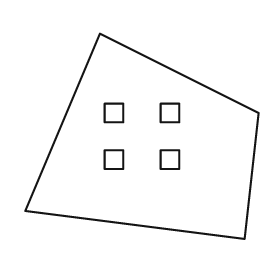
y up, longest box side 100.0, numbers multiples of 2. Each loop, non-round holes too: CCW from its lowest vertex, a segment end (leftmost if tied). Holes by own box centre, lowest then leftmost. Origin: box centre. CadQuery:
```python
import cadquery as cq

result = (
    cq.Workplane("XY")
    .moveTo(44.0, -44.0)
    .lineTo(50.0, 10.0)
    .lineTo(-18.0, 44.0)
    .lineTo(-50.0, -32.0)
    .close()
    .moveTo(-16.0, -14.0)
    .lineTo(-8.0, -14.0)
    .lineTo(-8.0, -6.0)
    .lineTo(-16.0, -6.0)
    .close()
    .moveTo(8.0, -14.0)
    .lineTo(16.0, -14.0)
    .lineTo(16.0, -6.0)
    .lineTo(8.0, -6.0)
    .close()
    .moveTo(-16.0, 6.0)
    .lineTo(-8.0, 6.0)
    .lineTo(-8.0, 14.0)
    .lineTo(-16.0, 14.0)
    .close()
    .moveTo(8.0, 6.0)
    .lineTo(16.0, 6.0)
    .lineTo(16.0, 14.0)
    .lineTo(8.0, 14.0)
    .close()
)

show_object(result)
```